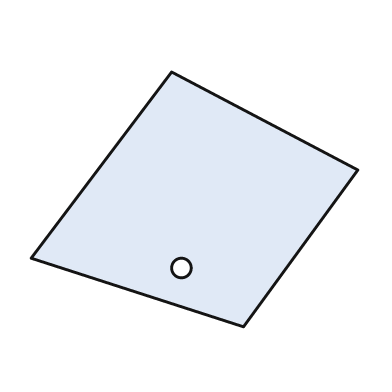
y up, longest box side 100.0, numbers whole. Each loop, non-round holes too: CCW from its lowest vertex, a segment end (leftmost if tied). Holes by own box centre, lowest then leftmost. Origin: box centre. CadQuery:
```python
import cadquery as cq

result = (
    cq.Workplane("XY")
    .moveTo(15.0, -39.0)
    .lineTo(50.0, 9.0)
    .lineTo(-7.0, 39.0)
    .lineTo(-50.0, -18.0)
    .close()
    .moveTo(-4.0, -21.0)
    .circle(3.0)
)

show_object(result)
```